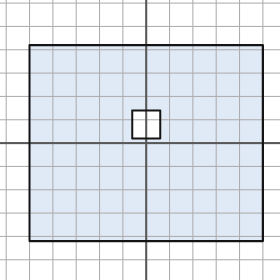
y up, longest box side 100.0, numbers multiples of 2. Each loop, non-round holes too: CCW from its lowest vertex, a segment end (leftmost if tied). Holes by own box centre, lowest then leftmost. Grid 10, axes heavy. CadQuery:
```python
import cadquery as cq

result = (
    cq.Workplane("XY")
    .moveTo(-50.0, -42.0)
    .lineTo(50.0, -42.0)
    .lineTo(50.0, 42.0)
    .lineTo(-50.0, 42.0)
    .close()
    .moveTo(-6.0, 2.0)
    .lineTo(6.0, 2.0)
    .lineTo(6.0, 14.0)
    .lineTo(-6.0, 14.0)
    .close()
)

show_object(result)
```